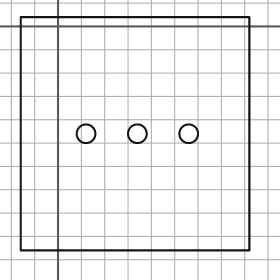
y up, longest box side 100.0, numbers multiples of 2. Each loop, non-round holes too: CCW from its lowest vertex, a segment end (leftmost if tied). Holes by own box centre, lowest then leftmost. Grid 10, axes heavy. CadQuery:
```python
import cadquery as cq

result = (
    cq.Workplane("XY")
    .moveTo(-16.0, -96.0)
    .lineTo(82.0, -96.0)
    .lineTo(82.0, 4.0)
    .lineTo(-16.0, 4.0)
    .close()
    .moveTo(12.0, -46.0)
    .circle(4.0)
    .moveTo(34.0, -46.0)
    .circle(4.0)
    .moveTo(56.0, -46.0)
    .circle(4.0)
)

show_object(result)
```